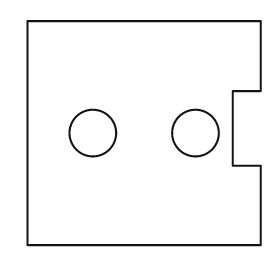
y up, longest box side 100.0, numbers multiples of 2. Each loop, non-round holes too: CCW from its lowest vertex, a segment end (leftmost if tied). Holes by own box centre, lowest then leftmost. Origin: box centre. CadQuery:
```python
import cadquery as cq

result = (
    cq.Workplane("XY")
    .moveTo(-50.0, -48.0)
    .lineTo(50.0, -48.0)
    .lineTo(50.0, -14.0)
    .lineTo(38.0, -14.0)
    .lineTo(38.0, 18.0)
    .lineTo(50.0, 18.0)
    .lineTo(50.0, 48.0)
    .lineTo(-50.0, 48.0)
    .close()
    .moveTo(-22.0, 0.0)
    .circle(10.0)
    .moveTo(22.0, 0.0)
    .circle(10.0)
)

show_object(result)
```